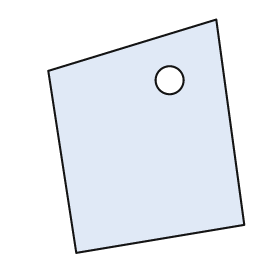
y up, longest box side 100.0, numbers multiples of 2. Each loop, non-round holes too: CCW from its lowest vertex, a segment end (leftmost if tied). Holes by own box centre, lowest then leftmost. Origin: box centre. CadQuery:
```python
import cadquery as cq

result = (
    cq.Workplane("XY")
    .moveTo(-30.0, -50.0)
    .lineTo(42.0, -38.0)
    .lineTo(30.0, 50.0)
    .lineTo(-42.0, 28.0)
    .close()
    .moveTo(10.0, 24.0)
    .circle(6.0)
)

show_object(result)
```